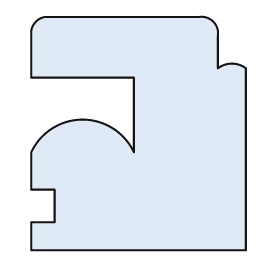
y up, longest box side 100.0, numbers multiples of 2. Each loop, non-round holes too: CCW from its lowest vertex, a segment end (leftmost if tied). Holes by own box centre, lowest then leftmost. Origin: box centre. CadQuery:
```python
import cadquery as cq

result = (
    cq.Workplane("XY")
    .moveTo(-46.0, -50.0)
    .lineTo(46.0, -50.0)
    .lineTo(46.0, 28.0)
    .threePointArc((40.0, 30.0), (34.0, 28.0))
    .lineTo(34.0, 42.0)
    .threePointArc((32.0, 48.0), (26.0, 50.0))
    .lineTo(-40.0, 50.0)
    .threePointArc((-44.0, 48.0), (-46.0, 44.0))
    .lineTo(-46.0, 24.0)
    .lineTo(-2.0, 24.0)
    .lineTo(-2.0, -8.0)
    .threePointArc((-24.0, 6.0), (-46.0, -8.0))
    .lineTo(-46.0, -24.0)
    .lineTo(-36.0, -24.0)
    .lineTo(-36.0, -38.0)
    .lineTo(-46.0, -38.0)
    .close()
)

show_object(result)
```